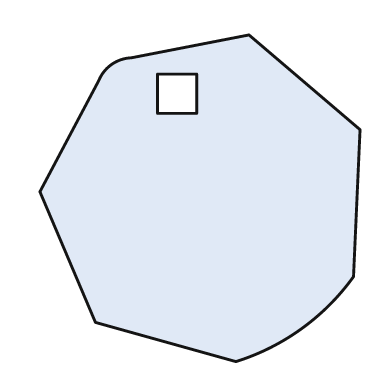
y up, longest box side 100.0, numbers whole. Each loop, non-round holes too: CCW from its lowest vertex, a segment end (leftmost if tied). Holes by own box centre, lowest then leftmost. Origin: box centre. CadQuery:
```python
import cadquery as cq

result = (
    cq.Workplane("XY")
    .moveTo(11.0, -50.0)
    .threePointArc((31.0, -40.0), (47.0, -24.0))
    .lineTo(49.0, 21.0)
    .lineTo(15.0, 50.0)
    .lineTo(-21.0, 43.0)
    .threePointArc((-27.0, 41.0), (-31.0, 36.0))
    .lineTo(-49.0, 2.0)
    .lineTo(-32.0, -38.0)
    .close()
    .moveTo(-13.0, 26.0)
    .lineTo(-1.0, 26.0)
    .lineTo(-1.0, 38.0)
    .lineTo(-13.0, 38.0)
    .close()
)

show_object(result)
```